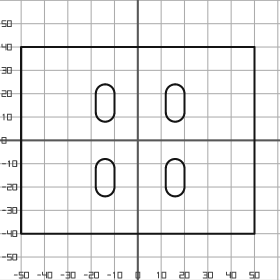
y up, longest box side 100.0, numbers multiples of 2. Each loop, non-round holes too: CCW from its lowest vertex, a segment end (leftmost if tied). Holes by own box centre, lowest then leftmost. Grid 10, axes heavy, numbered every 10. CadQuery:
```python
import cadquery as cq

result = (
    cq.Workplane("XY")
    .moveTo(-50.0, -40.0)
    .lineTo(50.0, -40.0)
    .lineTo(50.0, 40.0)
    .lineTo(-50.0, 40.0)
    .close()
    .moveTo(-18.0, -20.0)
    .threePointArc((-14.0, -24.0), (-10.0, -20.0))
    .lineTo(-10.0, -12.0)
    .threePointArc((-14.0, -8.0), (-18.0, -12.0))
    .close()
    .moveTo(12.0, -20.0)
    .threePointArc((16.0, -24.0), (20.0, -20.0))
    .lineTo(20.0, -12.0)
    .threePointArc((16.0, -8.0), (12.0, -12.0))
    .close()
    .moveTo(-18.0, 12.0)
    .threePointArc((-14.0, 8.0), (-10.0, 12.0))
    .lineTo(-10.0, 20.0)
    .threePointArc((-14.0, 24.0), (-18.0, 20.0))
    .close()
    .moveTo(12.0, 12.0)
    .threePointArc((16.0, 8.0), (20.0, 12.0))
    .lineTo(20.0, 20.0)
    .threePointArc((16.0, 24.0), (12.0, 20.0))
    .close()
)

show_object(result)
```